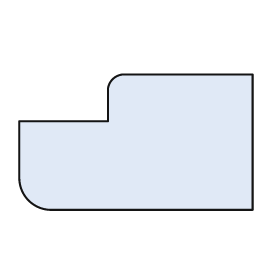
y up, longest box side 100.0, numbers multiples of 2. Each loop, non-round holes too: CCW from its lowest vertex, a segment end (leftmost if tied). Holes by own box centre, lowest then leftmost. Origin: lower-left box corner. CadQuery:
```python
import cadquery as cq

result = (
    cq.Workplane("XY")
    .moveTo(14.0, 0.0)
    .lineTo(100.0, 0.0)
    .lineTo(100.0, 58.0)
    .lineTo(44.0, 58.0)
    .threePointArc((40.0, 56.0), (38.0, 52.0))
    .lineTo(38.0, 38.0)
    .lineTo(0.0, 38.0)
    .lineTo(0.0, 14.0)
    .threePointArc((4.0, 4.0), (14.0, 0.0))
    .close()
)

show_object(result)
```